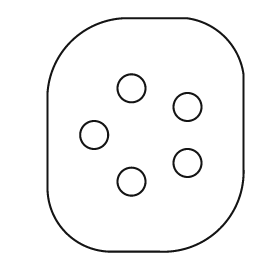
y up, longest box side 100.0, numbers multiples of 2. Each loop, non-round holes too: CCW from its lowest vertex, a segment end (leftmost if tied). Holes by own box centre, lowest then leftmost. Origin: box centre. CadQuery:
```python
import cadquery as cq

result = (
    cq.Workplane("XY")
    .moveTo(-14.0, -50.0)
    .lineTo(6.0, -50.0)
    .threePointArc((32.0, -40.0), (42.0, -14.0))
    .lineTo(42.0, 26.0)
    .threePointArc((34.0, 42.0), (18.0, 50.0))
    .lineTo(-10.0, 50.0)
    .threePointArc((-32.0, 40.0), (-42.0, 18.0))
    .lineTo(-42.0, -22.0)
    .threePointArc((-34.0, -42.0), (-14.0, -50.0))
    .close()
    .moveTo(-6.0, -20.0)
    .circle(6.0)
    .moveTo(18.0, -12.0)
    .circle(6.0)
    .moveTo(-22.0, 0.0)
    .circle(6.0)
    .moveTo(18.0, 12.0)
    .circle(6.0)
    .moveTo(-6.0, 20.0)
    .circle(6.0)
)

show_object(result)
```